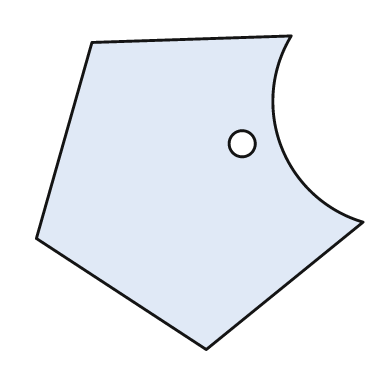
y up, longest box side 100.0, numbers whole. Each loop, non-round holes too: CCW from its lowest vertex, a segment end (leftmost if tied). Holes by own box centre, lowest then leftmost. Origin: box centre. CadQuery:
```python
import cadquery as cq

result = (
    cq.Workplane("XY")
    .moveTo(2.0, -48.0)
    .lineTo(50.0, -9.0)
    .threePointArc((25.0, 14.0), (28.0, 48.0))
    .lineTo(-33.0, 46.0)
    .lineTo(-50.0, -14.0)
    .close()
    .moveTo(13.0, 15.0)
    .circle(4.0)
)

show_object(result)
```